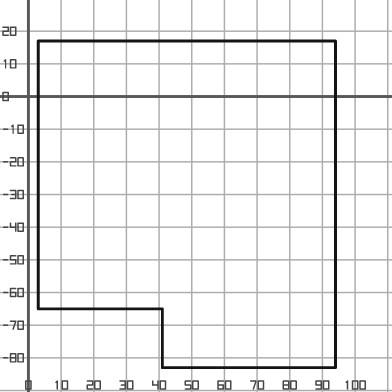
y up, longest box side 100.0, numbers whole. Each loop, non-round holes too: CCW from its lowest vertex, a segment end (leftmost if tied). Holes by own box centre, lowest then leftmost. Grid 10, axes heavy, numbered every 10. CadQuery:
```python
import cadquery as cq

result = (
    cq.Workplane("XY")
    .moveTo(41.0, -83.0)
    .lineTo(94.0, -83.0)
    .lineTo(94.0, 17.0)
    .lineTo(3.0, 17.0)
    .lineTo(3.0, -65.0)
    .lineTo(41.0, -65.0)
    .close()
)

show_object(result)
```